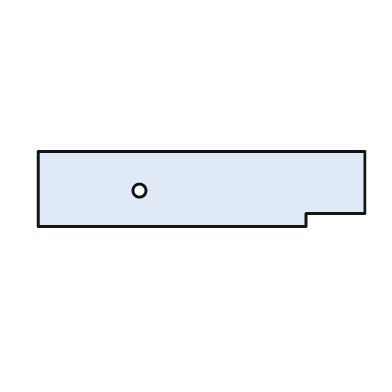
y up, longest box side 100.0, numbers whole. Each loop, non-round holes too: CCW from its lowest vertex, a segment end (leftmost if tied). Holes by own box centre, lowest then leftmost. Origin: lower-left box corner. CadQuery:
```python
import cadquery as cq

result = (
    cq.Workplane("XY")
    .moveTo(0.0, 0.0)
    .lineTo(82.0, 0.0)
    .lineTo(82.0, 4.0)
    .lineTo(100.0, 4.0)
    .lineTo(100.0, 23.0)
    .lineTo(0.0, 23.0)
    .close()
    .moveTo(31.0, 11.0)
    .circle(2.0)
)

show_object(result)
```